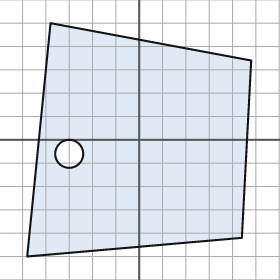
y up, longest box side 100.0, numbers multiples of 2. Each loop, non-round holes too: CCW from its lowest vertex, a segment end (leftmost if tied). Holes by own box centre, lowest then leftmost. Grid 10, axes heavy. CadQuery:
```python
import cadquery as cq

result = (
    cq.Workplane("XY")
    .moveTo(-48.0, -50.0)
    .lineTo(44.0, -42.0)
    .lineTo(48.0, 34.0)
    .lineTo(-38.0, 50.0)
    .close()
    .moveTo(-30.0, -6.0)
    .circle(6.0)
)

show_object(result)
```